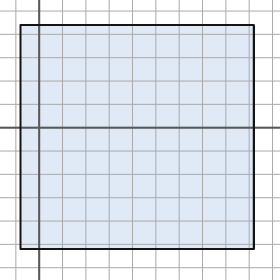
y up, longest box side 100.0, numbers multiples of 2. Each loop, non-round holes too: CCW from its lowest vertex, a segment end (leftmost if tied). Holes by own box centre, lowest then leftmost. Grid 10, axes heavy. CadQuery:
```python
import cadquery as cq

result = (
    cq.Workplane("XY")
    .moveTo(-8.0, -52.0)
    .lineTo(92.0, -52.0)
    .lineTo(92.0, 44.0)
    .lineTo(-8.0, 44.0)
    .close()
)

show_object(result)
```